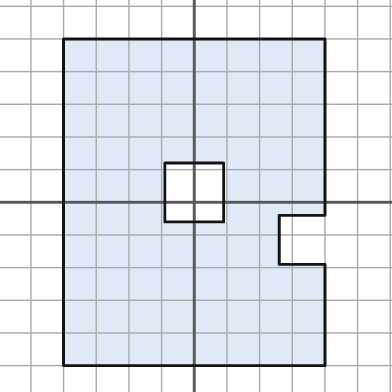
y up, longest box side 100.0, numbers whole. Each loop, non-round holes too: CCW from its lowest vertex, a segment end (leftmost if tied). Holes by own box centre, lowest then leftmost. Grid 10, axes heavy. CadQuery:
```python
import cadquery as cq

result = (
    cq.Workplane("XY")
    .moveTo(-40.0, -50.0)
    .lineTo(40.0, -50.0)
    .lineTo(40.0, -19.0)
    .lineTo(26.0, -19.0)
    .lineTo(26.0, -4.0)
    .lineTo(40.0, -4.0)
    .lineTo(40.0, 50.0)
    .lineTo(-40.0, 50.0)
    .close()
    .moveTo(-9.0, -6.0)
    .lineTo(9.0, -6.0)
    .lineTo(9.0, 12.0)
    .lineTo(-9.0, 12.0)
    .close()
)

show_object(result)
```